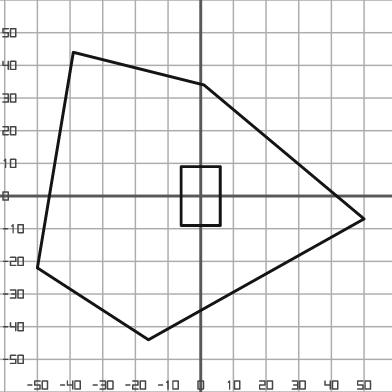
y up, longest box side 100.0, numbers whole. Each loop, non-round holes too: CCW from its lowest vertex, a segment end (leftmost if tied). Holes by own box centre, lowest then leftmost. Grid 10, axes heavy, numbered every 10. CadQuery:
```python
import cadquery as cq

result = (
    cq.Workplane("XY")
    .moveTo(-16.0, -44.0)
    .lineTo(50.0, -7.0)
    .lineTo(1.0, 34.0)
    .lineTo(-39.0, 44.0)
    .lineTo(-50.0, -22.0)
    .close()
    .moveTo(-6.0, -9.0)
    .lineTo(6.0, -9.0)
    .lineTo(6.0, 9.0)
    .lineTo(-6.0, 9.0)
    .close()
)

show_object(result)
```